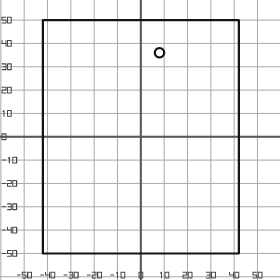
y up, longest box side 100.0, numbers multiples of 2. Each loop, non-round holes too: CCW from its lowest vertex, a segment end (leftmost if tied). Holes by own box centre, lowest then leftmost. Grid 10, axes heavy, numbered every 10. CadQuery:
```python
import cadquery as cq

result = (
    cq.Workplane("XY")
    .moveTo(-42.0, -50.0)
    .lineTo(42.0, -50.0)
    .lineTo(42.0, 50.0)
    .lineTo(-42.0, 50.0)
    .close()
    .moveTo(8.0, 36.0)
    .circle(2.0)
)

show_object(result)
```